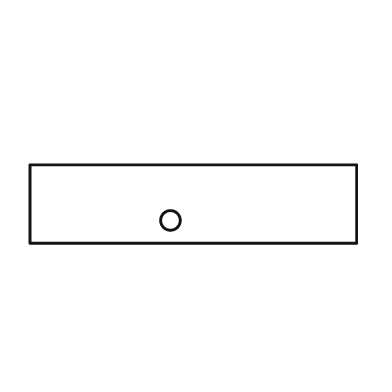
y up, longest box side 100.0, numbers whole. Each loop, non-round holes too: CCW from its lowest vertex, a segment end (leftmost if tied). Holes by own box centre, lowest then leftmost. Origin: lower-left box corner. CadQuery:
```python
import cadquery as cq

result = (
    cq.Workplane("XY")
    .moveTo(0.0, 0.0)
    .lineTo(100.0, 0.0)
    .lineTo(100.0, 24.0)
    .lineTo(0.0, 24.0)
    .close()
    .moveTo(43.0, 7.0)
    .circle(3.0)
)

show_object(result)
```